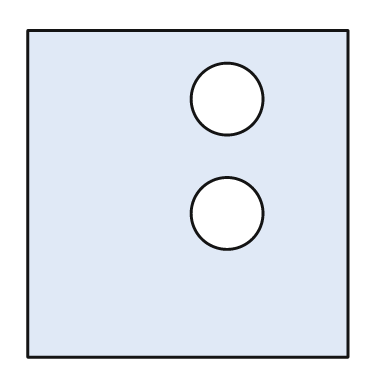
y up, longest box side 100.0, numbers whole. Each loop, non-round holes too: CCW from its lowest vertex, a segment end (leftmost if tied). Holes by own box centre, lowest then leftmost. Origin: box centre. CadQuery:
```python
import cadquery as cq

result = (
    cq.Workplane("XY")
    .moveTo(-49.0, -50.0)
    .lineTo(49.0, -50.0)
    .lineTo(49.0, 50.0)
    .lineTo(-49.0, 50.0)
    .close()
    .moveTo(12.0, -6.0)
    .circle(11.0)
    .moveTo(12.0, 29.0)
    .circle(11.0)
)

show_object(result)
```